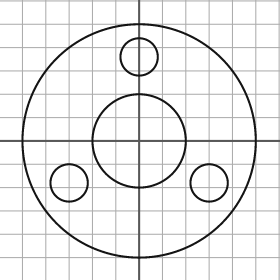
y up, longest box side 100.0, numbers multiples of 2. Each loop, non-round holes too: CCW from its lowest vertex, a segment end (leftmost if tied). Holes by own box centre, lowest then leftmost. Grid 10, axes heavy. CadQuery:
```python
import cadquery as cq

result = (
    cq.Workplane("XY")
    .moveTo(0.0, 0.0)
    .circle(50.0)
    .moveTo(-30.0, -18.0)
    .circle(8.0)
    .moveTo(30.0, -18.0)
    .circle(8.0)
    .moveTo(0.0, 0.0)
    .circle(20.0)
    .moveTo(0.0, 36.0)
    .circle(8.0)
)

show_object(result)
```